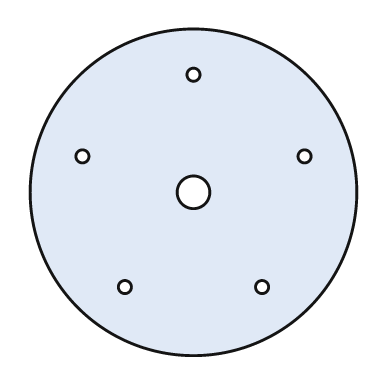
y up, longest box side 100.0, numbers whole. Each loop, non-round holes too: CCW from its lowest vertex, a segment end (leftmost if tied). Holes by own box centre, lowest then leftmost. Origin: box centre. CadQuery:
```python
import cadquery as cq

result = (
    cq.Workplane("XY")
    .moveTo(0.0, 0.0)
    .circle(50.0)
    .moveTo(-21.0, -29.0)
    .circle(2.0)
    .moveTo(21.0, -29.0)
    .circle(2.0)
    .moveTo(0.0, 0.0)
    .circle(5.0)
    .moveTo(-34.0, 11.0)
    .circle(2.0)
    .moveTo(34.0, 11.0)
    .circle(2.0)
    .moveTo(0.0, 36.0)
    .circle(2.0)
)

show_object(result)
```